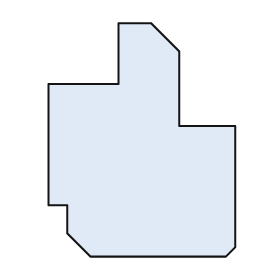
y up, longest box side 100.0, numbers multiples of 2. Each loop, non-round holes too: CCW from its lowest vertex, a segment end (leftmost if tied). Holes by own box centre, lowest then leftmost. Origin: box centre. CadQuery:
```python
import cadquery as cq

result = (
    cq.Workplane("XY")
    .moveTo(-22.0, -50.0)
    .lineTo(36.0, -50.0)
    .lineTo(40.0, -46.0)
    .lineTo(40.0, 6.0)
    .lineTo(16.0, 6.0)
    .lineTo(16.0, 38.0)
    .lineTo(4.0, 50.0)
    .lineTo(-10.0, 50.0)
    .lineTo(-10.0, 24.0)
    .lineTo(-40.0, 24.0)
    .lineTo(-40.0, -28.0)
    .lineTo(-32.0, -28.0)
    .lineTo(-32.0, -40.0)
    .close()
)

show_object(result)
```